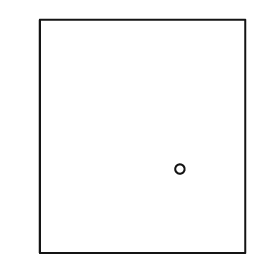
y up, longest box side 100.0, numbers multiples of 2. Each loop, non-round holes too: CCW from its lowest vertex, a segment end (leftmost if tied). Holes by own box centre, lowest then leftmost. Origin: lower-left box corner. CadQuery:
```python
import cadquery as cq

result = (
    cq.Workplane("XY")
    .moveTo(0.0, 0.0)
    .lineTo(88.0, 0.0)
    .lineTo(88.0, 100.0)
    .lineTo(0.0, 100.0)
    .close()
    .moveTo(60.0, 36.0)
    .circle(2.0)
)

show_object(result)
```